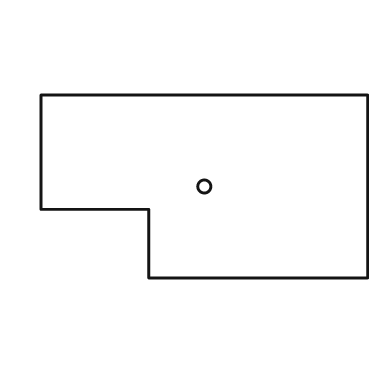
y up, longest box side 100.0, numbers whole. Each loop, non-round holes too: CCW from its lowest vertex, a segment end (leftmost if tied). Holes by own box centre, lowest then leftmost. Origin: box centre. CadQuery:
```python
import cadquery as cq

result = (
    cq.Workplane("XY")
    .moveTo(-17.0, -28.0)
    .lineTo(50.0, -28.0)
    .lineTo(50.0, 28.0)
    .lineTo(-50.0, 28.0)
    .lineTo(-50.0, -7.0)
    .lineTo(-17.0, -7.0)
    .close()
    .moveTo(0.0, 0.0)
    .circle(2.0)
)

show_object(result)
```